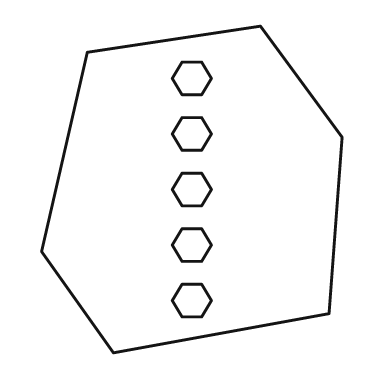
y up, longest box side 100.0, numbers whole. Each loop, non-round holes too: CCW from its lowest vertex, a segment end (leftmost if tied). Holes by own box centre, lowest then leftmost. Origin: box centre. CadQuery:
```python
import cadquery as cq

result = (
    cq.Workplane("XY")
    .moveTo(-24.0, -50.0)
    .lineTo(42.0, -38.0)
    .lineTo(46.0, 16.0)
    .lineTo(21.0, 50.0)
    .lineTo(-32.0, 42.0)
    .lineTo(-46.0, -19.0)
    .close()
    .moveTo(-3.0, -39.0)
    .lineTo(3.0, -39.0)
    .lineTo(6.0, -34.0)
    .lineTo(3.0, -29.0)
    .lineTo(-3.0, -29.0)
    .lineTo(-6.0, -34.0)
    .close()
    .moveTo(-3.0, -22.0)
    .lineTo(3.0, -22.0)
    .lineTo(6.0, -17.0)
    .lineTo(3.0, -12.0)
    .lineTo(-3.0, -12.0)
    .lineTo(-6.0, -17.0)
    .close()
    .moveTo(-3.0, -5.0)
    .lineTo(3.0, -5.0)
    .lineTo(6.0, 0.0)
    .lineTo(3.0, 5.0)
    .lineTo(-3.0, 5.0)
    .lineTo(-6.0, 0.0)
    .close()
    .moveTo(-3.0, 12.0)
    .lineTo(3.0, 12.0)
    .lineTo(6.0, 17.0)
    .lineTo(3.0, 22.0)
    .lineTo(-3.0, 22.0)
    .lineTo(-6.0, 17.0)
    .close()
    .moveTo(-3.0, 29.0)
    .lineTo(3.0, 29.0)
    .lineTo(6.0, 34.0)
    .lineTo(3.0, 39.0)
    .lineTo(-3.0, 39.0)
    .lineTo(-6.0, 34.0)
    .close()
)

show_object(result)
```